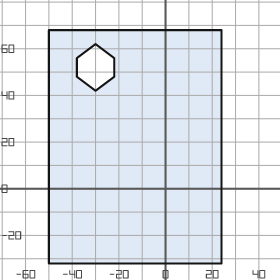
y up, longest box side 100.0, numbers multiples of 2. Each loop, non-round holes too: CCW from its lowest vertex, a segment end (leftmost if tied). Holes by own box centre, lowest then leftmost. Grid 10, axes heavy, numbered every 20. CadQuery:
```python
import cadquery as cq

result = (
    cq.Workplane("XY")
    .moveTo(-50.0, -32.0)
    .lineTo(24.0, -32.0)
    .lineTo(24.0, 68.0)
    .lineTo(-50.0, 68.0)
    .close()
    .moveTo(-30.0, 42.0)
    .lineTo(-22.0, 48.0)
    .lineTo(-22.0, 56.0)
    .lineTo(-30.0, 62.0)
    .lineTo(-38.0, 56.0)
    .lineTo(-38.0, 48.0)
    .close()
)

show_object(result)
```